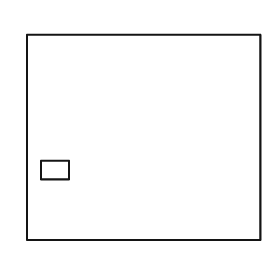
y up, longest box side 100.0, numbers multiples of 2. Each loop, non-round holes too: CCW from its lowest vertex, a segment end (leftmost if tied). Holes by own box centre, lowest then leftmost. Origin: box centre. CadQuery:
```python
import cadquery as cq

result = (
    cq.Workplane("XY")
    .moveTo(-50.0, -44.0)
    .lineTo(50.0, -44.0)
    .lineTo(50.0, 44.0)
    .lineTo(-50.0, 44.0)
    .close()
    .moveTo(-44.0, -18.0)
    .lineTo(-32.0, -18.0)
    .lineTo(-32.0, -10.0)
    .lineTo(-44.0, -10.0)
    .close()
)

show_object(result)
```